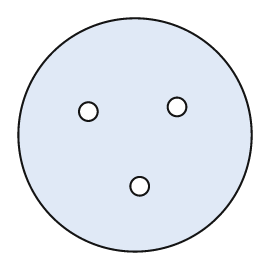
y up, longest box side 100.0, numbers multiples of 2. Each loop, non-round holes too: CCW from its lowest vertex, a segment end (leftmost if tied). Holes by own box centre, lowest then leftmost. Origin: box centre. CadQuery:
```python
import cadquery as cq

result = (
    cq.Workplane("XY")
    .moveTo(0.0, 0.0)
    .circle(50.0)
    .moveTo(2.0, -22.0)
    .circle(4.0)
    .moveTo(-20.0, 10.0)
    .circle(4.0)
    .moveTo(18.0, 12.0)
    .circle(4.0)
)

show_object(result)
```